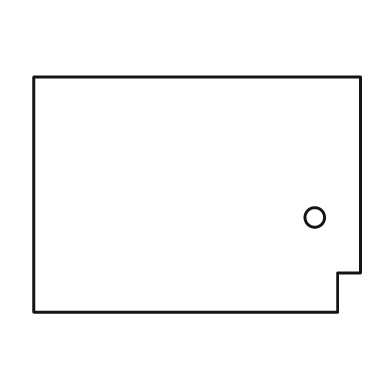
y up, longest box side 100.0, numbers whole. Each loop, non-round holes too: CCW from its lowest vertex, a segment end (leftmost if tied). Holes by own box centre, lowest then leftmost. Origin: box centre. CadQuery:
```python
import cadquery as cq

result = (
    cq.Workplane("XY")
    .moveTo(-50.0, -36.0)
    .lineTo(43.0, -36.0)
    .lineTo(43.0, -24.0)
    .lineTo(50.0, -24.0)
    .lineTo(50.0, 36.0)
    .lineTo(-50.0, 36.0)
    .close()
    .moveTo(36.0, -7.0)
    .circle(3.0)
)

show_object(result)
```